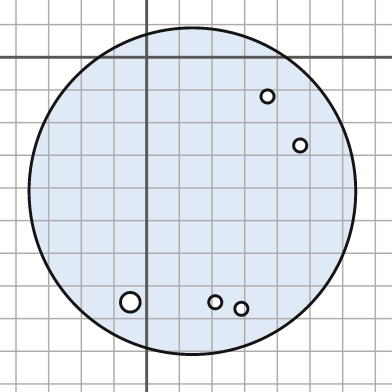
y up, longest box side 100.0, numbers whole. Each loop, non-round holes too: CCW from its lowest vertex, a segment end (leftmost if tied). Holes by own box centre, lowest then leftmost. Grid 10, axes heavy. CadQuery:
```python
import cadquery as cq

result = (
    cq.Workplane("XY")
    .moveTo(14.0, -41.0)
    .circle(50.0)
    .moveTo(29.0, -77.0)
    .circle(2.0)
    .moveTo(-5.0, -75.0)
    .circle(3.0)
    .moveTo(21.0, -75.0)
    .circle(2.0)
    .moveTo(47.0, -27.0)
    .circle(2.0)
    .moveTo(37.0, -12.0)
    .circle(2.0)
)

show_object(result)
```